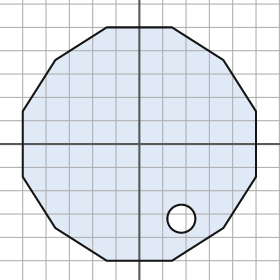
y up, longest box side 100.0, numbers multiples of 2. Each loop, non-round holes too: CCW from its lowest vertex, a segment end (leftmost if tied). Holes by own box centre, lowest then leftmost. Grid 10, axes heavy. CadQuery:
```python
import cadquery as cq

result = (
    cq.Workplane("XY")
    .moveTo(-14.0, -50.0)
    .lineTo(14.0, -50.0)
    .lineTo(36.0, -36.0)
    .lineTo(50.0, -14.0)
    .lineTo(50.0, 14.0)
    .lineTo(36.0, 36.0)
    .lineTo(14.0, 50.0)
    .lineTo(-14.0, 50.0)
    .lineTo(-36.0, 36.0)
    .lineTo(-50.0, 14.0)
    .lineTo(-50.0, -14.0)
    .lineTo(-36.0, -36.0)
    .close()
    .moveTo(18.0, -32.0)
    .circle(6.0)
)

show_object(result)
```